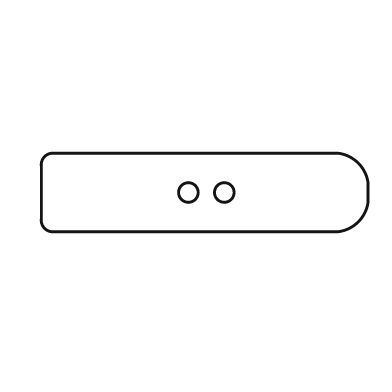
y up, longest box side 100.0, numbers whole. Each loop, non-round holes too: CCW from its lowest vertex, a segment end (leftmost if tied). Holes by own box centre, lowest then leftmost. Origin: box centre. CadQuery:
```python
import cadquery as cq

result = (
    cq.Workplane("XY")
    .moveTo(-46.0, -12.0)
    .lineTo(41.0, -12.0)
    .threePointArc((47.0, -9.0), (50.0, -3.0))
    .lineTo(50.0, 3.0)
    .threePointArc((47.0, 9.0), (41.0, 12.0))
    .lineTo(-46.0, 12.0)
    .threePointArc((-49.0, 11.0), (-50.0, 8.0))
    .lineTo(-50.0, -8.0)
    .threePointArc((-49.0, -11.0), (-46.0, -12.0))
    .close()
    .moveTo(-5.0, 0.0)
    .circle(3.0)
    .moveTo(6.0, 0.0)
    .circle(3.0)
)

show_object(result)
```